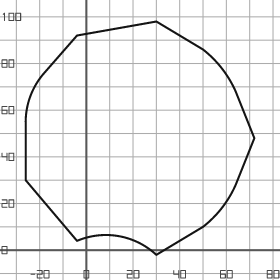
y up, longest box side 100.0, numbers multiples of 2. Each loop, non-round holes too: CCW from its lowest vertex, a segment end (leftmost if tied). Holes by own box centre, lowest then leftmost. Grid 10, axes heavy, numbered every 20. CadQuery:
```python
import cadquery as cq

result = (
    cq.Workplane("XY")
    .moveTo(30.0, -2.0)
    .lineTo(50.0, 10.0)
    .threePointArc((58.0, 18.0), (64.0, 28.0))
    .lineTo(72.0, 48.0)
    .lineTo(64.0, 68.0)
    .threePointArc((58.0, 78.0), (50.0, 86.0))
    .lineTo(30.0, 98.0)
    .lineTo(-4.0, 92.0)
    .lineTo(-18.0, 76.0)
    .threePointArc((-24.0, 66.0), (-26.0, 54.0))
    .lineTo(-26.0, 30.0)
    .lineTo(-4.0, 4.0)
    .threePointArc((14.0, 6.0), (30.0, -2.0))
    .close()
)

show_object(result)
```